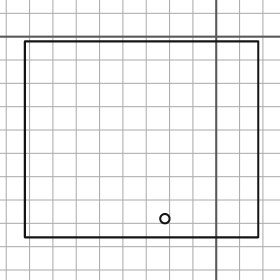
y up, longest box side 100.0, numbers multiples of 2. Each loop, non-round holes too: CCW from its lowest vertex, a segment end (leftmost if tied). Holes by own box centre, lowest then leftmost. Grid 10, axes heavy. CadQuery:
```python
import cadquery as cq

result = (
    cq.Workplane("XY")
    .moveTo(-82.0, -86.0)
    .lineTo(18.0, -86.0)
    .lineTo(18.0, -2.0)
    .lineTo(-82.0, -2.0)
    .close()
    .moveTo(-22.0, -78.0)
    .circle(2.0)
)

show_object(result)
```